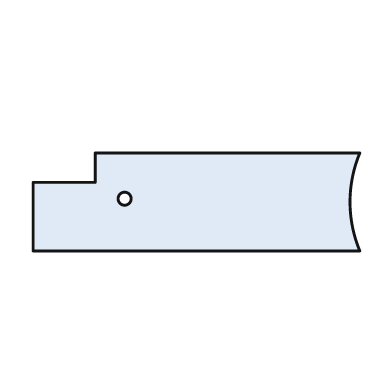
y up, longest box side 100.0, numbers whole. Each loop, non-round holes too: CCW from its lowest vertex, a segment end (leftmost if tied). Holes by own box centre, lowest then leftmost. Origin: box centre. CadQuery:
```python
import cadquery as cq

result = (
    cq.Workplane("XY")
    .moveTo(-50.0, -15.0)
    .lineTo(50.0, -15.0)
    .threePointArc((47.0, 0.0), (50.0, 15.0))
    .lineTo(-31.0, 15.0)
    .lineTo(-31.0, 6.0)
    .lineTo(-50.0, 6.0)
    .close()
    .moveTo(-22.0, 1.0)
    .circle(2.0)
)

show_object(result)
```